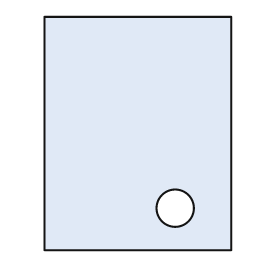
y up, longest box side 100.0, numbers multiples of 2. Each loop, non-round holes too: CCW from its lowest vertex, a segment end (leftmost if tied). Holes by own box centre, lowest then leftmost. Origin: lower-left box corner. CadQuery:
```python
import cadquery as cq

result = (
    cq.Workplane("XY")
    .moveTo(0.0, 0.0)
    .lineTo(80.0, 0.0)
    .lineTo(80.0, 100.0)
    .lineTo(0.0, 100.0)
    .close()
    .moveTo(56.0, 18.0)
    .circle(8.0)
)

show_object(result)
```